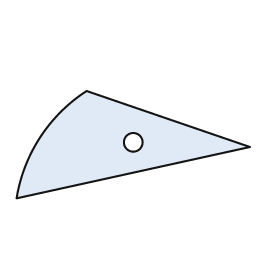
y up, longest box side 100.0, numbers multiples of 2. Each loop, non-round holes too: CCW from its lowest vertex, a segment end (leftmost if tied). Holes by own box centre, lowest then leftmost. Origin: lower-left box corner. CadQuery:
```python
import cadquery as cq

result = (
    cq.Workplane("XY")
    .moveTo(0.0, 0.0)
    .lineTo(100.0, 22.0)
    .lineTo(30.0, 46.0)
    .threePointArc((10.0, 26.0), (0.0, 0.0))
    .close()
    .moveTo(50.0, 24.0)
    .circle(4.0)
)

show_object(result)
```